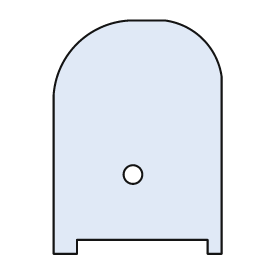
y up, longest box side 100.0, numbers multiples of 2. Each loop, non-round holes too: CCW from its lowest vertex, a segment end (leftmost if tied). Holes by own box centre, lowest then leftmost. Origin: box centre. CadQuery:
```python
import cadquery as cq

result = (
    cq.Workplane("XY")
    .moveTo(-36.0, -50.0)
    .lineTo(-26.0, -50.0)
    .lineTo(-26.0, -44.0)
    .lineTo(30.0, -44.0)
    .lineTo(30.0, -50.0)
    .lineTo(36.0, -50.0)
    .lineTo(36.0, 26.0)
    .threePointArc((28.0, 42.0), (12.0, 50.0))
    .lineTo(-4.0, 50.0)
    .threePointArc((-26.0, 40.0), (-36.0, 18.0))
    .close()
    .moveTo(-2.0, -16.0)
    .circle(4.0)
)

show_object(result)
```